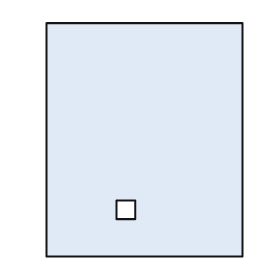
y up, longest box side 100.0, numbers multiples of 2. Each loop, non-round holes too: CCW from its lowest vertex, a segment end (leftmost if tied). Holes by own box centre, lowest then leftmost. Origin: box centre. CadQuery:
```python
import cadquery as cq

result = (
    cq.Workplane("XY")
    .moveTo(-42.0, -50.0)
    .lineTo(42.0, -50.0)
    .lineTo(42.0, 50.0)
    .lineTo(-42.0, 50.0)
    .close()
    .moveTo(-12.0, -34.0)
    .lineTo(-4.0, -34.0)
    .lineTo(-4.0, -26.0)
    .lineTo(-12.0, -26.0)
    .close()
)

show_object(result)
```